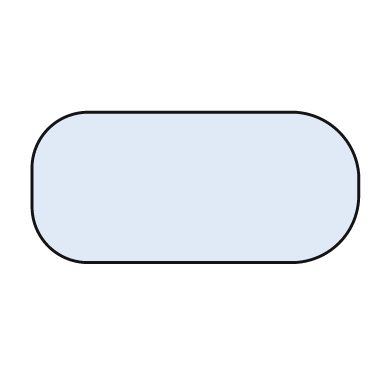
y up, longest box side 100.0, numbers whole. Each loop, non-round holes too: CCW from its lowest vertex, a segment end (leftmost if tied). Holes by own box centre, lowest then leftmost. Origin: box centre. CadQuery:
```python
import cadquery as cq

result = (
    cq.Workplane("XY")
    .moveTo(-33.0, -23.0)
    .lineTo(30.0, -23.0)
    .threePointArc((44.0, -17.0), (50.0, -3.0))
    .lineTo(50.0, 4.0)
    .threePointArc((44.0, 17.0), (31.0, 23.0))
    .lineTo(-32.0, 23.0)
    .threePointArc((-45.0, 18.0), (-50.0, 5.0))
    .lineTo(-50.0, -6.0)
    .threePointArc((-45.0, -18.0), (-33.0, -23.0))
    .close()
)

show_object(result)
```